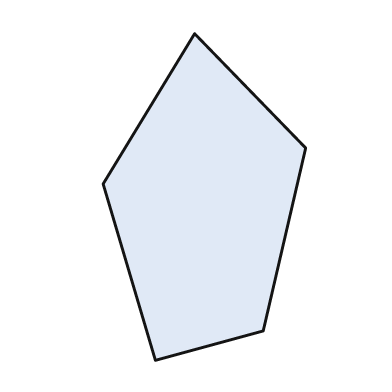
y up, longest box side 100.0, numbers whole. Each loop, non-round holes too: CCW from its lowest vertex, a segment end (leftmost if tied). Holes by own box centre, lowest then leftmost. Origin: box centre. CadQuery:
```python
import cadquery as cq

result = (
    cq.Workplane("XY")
    .moveTo(-15.0, -50.0)
    .lineTo(18.0, -41.0)
    .lineTo(31.0, 15.0)
    .lineTo(-3.0, 50.0)
    .lineTo(-31.0, 4.0)
    .close()
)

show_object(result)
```